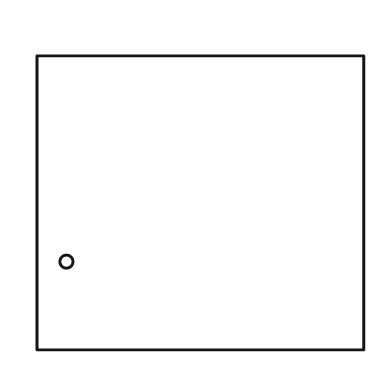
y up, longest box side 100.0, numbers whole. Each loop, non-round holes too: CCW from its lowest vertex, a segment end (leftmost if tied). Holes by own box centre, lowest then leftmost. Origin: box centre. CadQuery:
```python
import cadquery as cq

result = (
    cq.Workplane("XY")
    .moveTo(-50.0, -45.0)
    .lineTo(50.0, -45.0)
    .lineTo(50.0, 45.0)
    .lineTo(-50.0, 45.0)
    .close()
    .moveTo(-41.0, -18.0)
    .circle(2.0)
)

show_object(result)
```